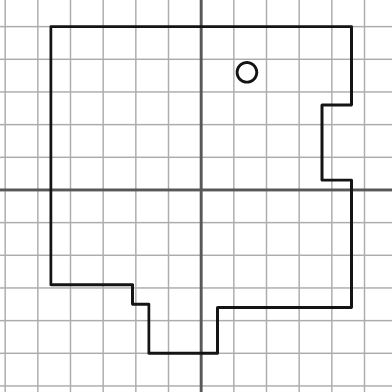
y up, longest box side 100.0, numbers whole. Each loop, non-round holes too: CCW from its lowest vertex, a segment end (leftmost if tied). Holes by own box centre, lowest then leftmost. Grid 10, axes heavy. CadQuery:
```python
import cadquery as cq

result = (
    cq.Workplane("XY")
    .moveTo(-16.0, -50.0)
    .lineTo(5.0, -50.0)
    .lineTo(5.0, -36.0)
    .lineTo(46.0, -36.0)
    .lineTo(46.0, 3.0)
    .lineTo(37.0, 3.0)
    .lineTo(37.0, 26.0)
    .lineTo(46.0, 26.0)
    .lineTo(46.0, 50.0)
    .lineTo(-46.0, 50.0)
    .lineTo(-46.0, -29.0)
    .lineTo(-21.0, -29.0)
    .lineTo(-21.0, -35.0)
    .lineTo(-16.0, -35.0)
    .close()
    .moveTo(14.0, 36.0)
    .circle(3.0)
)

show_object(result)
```